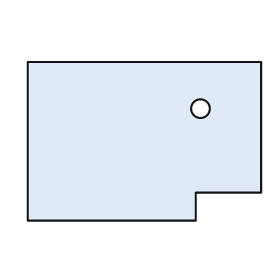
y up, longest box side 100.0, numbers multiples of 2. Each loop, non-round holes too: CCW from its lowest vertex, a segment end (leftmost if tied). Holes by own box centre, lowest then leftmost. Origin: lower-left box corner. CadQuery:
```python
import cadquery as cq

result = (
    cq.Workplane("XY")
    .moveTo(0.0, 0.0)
    .lineTo(72.0, 0.0)
    .lineTo(72.0, 12.0)
    .lineTo(100.0, 12.0)
    .lineTo(100.0, 68.0)
    .lineTo(0.0, 68.0)
    .close()
    .moveTo(74.0, 48.0)
    .circle(4.0)
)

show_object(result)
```